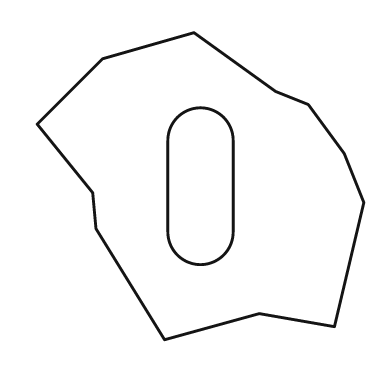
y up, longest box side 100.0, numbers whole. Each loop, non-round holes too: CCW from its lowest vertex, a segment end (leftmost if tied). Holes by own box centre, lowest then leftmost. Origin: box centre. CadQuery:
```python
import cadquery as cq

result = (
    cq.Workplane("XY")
    .moveTo(-11.0, -47.0)
    .lineTo(18.0, -39.0)
    .lineTo(41.0, -43.0)
    .lineTo(50.0, -5.0)
    .lineTo(44.0, 10.0)
    .lineTo(33.0, 25.0)
    .lineTo(23.0, 29.0)
    .lineTo(-2.0, 47.0)
    .lineTo(-30.0, 39.0)
    .lineTo(-50.0, 19.0)
    .lineTo(-33.0, -2.0)
    .lineTo(-32.0, -13.0)
    .close()
    .moveTo(-10.0, -14.0)
    .threePointArc((0.0, -24.0), (10.0, -14.0))
    .lineTo(10.0, 14.0)
    .threePointArc((0.0, 24.0), (-10.0, 14.0))
    .close()
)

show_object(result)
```